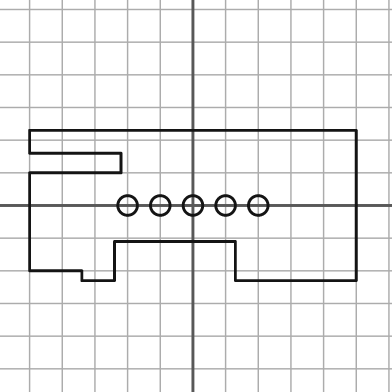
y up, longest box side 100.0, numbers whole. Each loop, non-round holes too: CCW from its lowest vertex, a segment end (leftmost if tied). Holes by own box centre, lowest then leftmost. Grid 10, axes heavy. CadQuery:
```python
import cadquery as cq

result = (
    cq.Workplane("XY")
    .moveTo(-34.0, -23.0)
    .lineTo(-24.0, -23.0)
    .lineTo(-24.0, -11.0)
    .lineTo(13.0, -11.0)
    .lineTo(13.0, -23.0)
    .lineTo(50.0, -23.0)
    .lineTo(50.0, 23.0)
    .lineTo(-50.0, 23.0)
    .lineTo(-50.0, 16.0)
    .lineTo(-22.0, 16.0)
    .lineTo(-22.0, 10.0)
    .lineTo(-50.0, 10.0)
    .lineTo(-50.0, -20.0)
    .lineTo(-34.0, -20.0)
    .close()
    .moveTo(-20.0, 0.0)
    .circle(3.0)
    .moveTo(-10.0, 0.0)
    .circle(3.0)
    .moveTo(0.0, 0.0)
    .circle(3.0)
    .moveTo(10.0, 0.0)
    .circle(3.0)
    .moveTo(20.0, 0.0)
    .circle(3.0)
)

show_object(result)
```